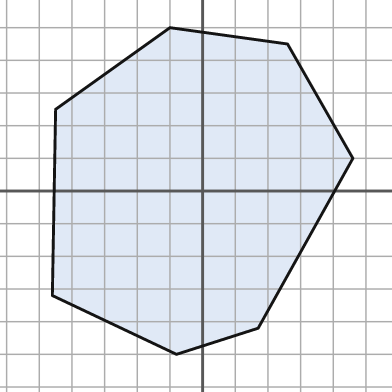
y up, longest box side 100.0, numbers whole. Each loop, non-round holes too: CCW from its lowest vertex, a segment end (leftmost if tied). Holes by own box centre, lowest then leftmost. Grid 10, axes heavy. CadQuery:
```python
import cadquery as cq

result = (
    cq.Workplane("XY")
    .moveTo(-8.0, -50.0)
    .lineTo(17.0, -42.0)
    .lineTo(46.0, 10.0)
    .lineTo(26.0, 45.0)
    .lineTo(-10.0, 50.0)
    .lineTo(-45.0, 25.0)
    .lineTo(-46.0, -32.0)
    .close()
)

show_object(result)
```